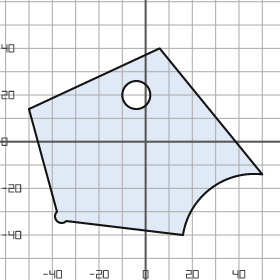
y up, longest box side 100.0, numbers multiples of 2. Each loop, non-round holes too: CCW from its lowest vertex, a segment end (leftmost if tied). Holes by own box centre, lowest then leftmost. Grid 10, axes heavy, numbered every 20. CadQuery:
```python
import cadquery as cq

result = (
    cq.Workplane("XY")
    .moveTo(16.0, -40.0)
    .threePointArc((28.0, -20.0), (50.0, -14.0))
    .lineTo(6.0, 40.0)
    .lineTo(-50.0, 14.0)
    .lineTo(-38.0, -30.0)
    .threePointArc((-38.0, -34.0), (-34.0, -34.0))
    .close()
    .moveTo(-4.0, 20.0)
    .circle(6.0)
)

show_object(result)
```